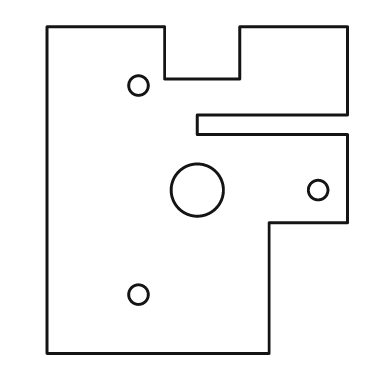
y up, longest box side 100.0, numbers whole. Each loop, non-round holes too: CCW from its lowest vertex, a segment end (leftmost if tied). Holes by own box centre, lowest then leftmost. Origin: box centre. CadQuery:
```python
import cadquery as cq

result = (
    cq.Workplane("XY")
    .moveTo(-46.0, -50.0)
    .lineTo(22.0, -50.0)
    .lineTo(22.0, -10.0)
    .lineTo(46.0, -10.0)
    .lineTo(46.0, 17.0)
    .lineTo(0.0, 17.0)
    .lineTo(0.0, 23.0)
    .lineTo(46.0, 23.0)
    .lineTo(46.0, 50.0)
    .lineTo(13.0, 50.0)
    .lineTo(13.0, 34.0)
    .lineTo(-10.0, 34.0)
    .lineTo(-10.0, 50.0)
    .lineTo(-46.0, 50.0)
    .close()
    .moveTo(-18.0, -32.0)
    .circle(3.0)
    .moveTo(0.0, 0.0)
    .circle(8.0)
    .moveTo(37.0, 0.0)
    .circle(3.0)
    .moveTo(-18.0, 32.0)
    .circle(3.0)
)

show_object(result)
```